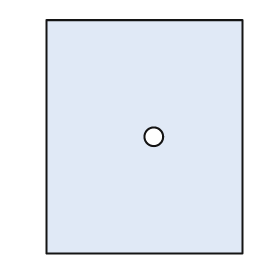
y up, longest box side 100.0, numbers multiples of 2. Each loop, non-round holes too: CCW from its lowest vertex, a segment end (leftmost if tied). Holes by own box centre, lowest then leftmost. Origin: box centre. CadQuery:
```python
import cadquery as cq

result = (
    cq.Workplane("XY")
    .moveTo(-42.0, -50.0)
    .lineTo(42.0, -50.0)
    .lineTo(42.0, 50.0)
    .lineTo(-42.0, 50.0)
    .close()
    .moveTo(4.0, 0.0)
    .circle(4.0)
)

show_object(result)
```